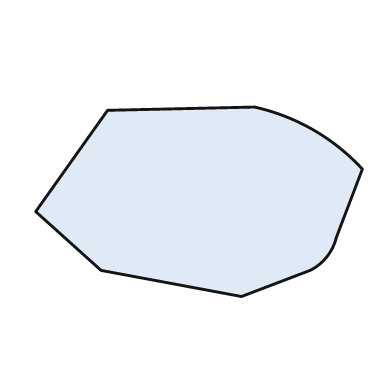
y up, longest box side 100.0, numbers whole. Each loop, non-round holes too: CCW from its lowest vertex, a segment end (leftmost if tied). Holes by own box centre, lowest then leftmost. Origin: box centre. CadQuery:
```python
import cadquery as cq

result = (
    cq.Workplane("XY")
    .moveTo(13.0, -29.0)
    .lineTo(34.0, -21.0)
    .threePointArc((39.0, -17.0), (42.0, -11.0))
    .lineTo(50.0, 10.0)
    .threePointArc((35.0, 22.0), (17.0, 29.0))
    .lineTo(-28.0, 28.0)
    .lineTo(-50.0, -3.0)
    .lineTo(-30.0, -21.0)
    .close()
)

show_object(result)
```